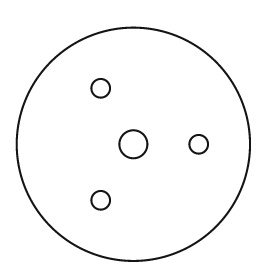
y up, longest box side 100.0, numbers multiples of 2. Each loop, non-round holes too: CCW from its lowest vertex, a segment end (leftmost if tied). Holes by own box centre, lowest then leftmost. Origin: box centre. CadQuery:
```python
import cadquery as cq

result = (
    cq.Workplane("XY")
    .moveTo(0.0, 0.0)
    .circle(50.0)
    .moveTo(-14.0, -24.0)
    .circle(4.0)
    .moveTo(0.0, 0.0)
    .circle(6.0)
    .moveTo(28.0, 0.0)
    .circle(4.0)
    .moveTo(-14.0, 24.0)
    .circle(4.0)
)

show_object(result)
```